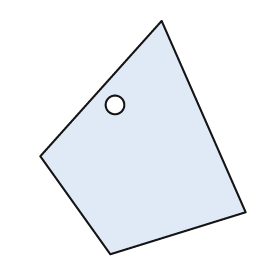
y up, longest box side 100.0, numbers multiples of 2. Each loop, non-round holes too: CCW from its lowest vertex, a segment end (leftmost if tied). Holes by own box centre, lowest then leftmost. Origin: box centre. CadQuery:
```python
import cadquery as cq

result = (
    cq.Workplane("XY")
    .moveTo(-14.0, -50.0)
    .lineTo(44.0, -32.0)
    .lineTo(8.0, 50.0)
    .lineTo(-44.0, -8.0)
    .close()
    .moveTo(-12.0, 14.0)
    .circle(4.0)
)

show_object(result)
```